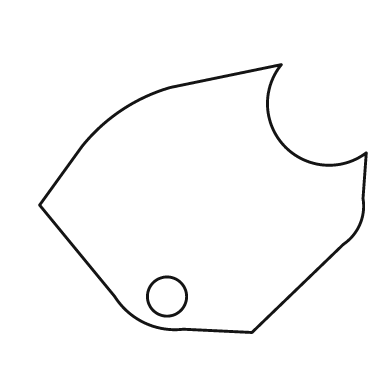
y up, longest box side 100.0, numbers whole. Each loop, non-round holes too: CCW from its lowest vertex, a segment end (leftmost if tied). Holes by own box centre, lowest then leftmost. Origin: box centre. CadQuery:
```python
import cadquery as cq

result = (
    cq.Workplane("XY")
    .moveTo(15.0, -41.0)
    .lineTo(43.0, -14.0)
    .threePointArc((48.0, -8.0), (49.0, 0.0))
    .lineTo(50.0, 14.0)
    .threePointArc((25.0, 16.0), (24.0, 41.0))
    .lineTo(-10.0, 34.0)
    .threePointArc((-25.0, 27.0), (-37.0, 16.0))
    .lineTo(-50.0, -2.0)
    .lineTo(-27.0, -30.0)
    .threePointArc((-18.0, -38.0), (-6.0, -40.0))
    .close()
    .moveTo(-11.0, -30.0)
    .circle(6.0)
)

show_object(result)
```